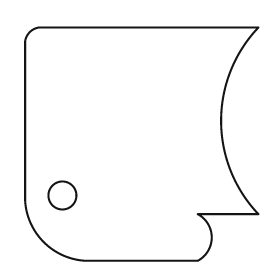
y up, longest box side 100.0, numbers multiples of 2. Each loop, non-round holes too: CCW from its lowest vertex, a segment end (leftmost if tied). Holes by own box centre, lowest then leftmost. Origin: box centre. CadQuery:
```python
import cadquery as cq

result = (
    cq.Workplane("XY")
    .moveTo(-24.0, -50.0)
    .lineTo(24.0, -50.0)
    .threePointArc((30.0, -40.0), (24.0, -30.0))
    .lineTo(50.0, -30.0)
    .threePointArc((34.0, 10.0), (50.0, 50.0))
    .lineTo(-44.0, 50.0)
    .threePointArc((-48.0, 48.0), (-50.0, 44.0))
    .lineTo(-50.0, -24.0)
    .threePointArc((-42.0, -42.0), (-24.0, -50.0))
    .close()
    .moveTo(-34.0, -22.0)
    .circle(6.0)
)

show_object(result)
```